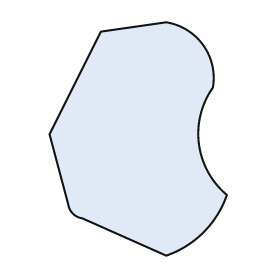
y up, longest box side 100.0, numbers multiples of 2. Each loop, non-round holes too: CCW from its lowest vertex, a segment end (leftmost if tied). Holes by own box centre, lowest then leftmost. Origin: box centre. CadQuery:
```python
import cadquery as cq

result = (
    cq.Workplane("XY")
    .moveTo(12.0, -50.0)
    .threePointArc((28.0, -40.0), (38.0, -24.0))
    .threePointArc((26.0, -2.0), (32.0, 22.0))
    .threePointArc((28.0, 40.0), (12.0, 50.0))
    .lineTo(-16.0, 46.0)
    .lineTo(-38.0, 2.0)
    .lineTo(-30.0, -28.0)
    .threePointArc((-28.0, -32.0), (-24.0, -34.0))
    .close()
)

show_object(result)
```